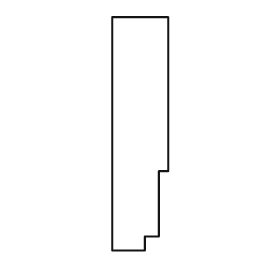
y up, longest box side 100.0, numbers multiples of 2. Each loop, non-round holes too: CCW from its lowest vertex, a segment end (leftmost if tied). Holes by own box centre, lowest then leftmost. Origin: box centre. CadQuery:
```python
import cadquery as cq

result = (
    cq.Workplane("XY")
    .moveTo(-12.0, -50.0)
    .lineTo(2.0, -50.0)
    .lineTo(2.0, -44.0)
    .lineTo(8.0, -44.0)
    .lineTo(8.0, -16.0)
    .lineTo(12.0, -16.0)
    .lineTo(12.0, 50.0)
    .lineTo(-12.0, 50.0)
    .close()
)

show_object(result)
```